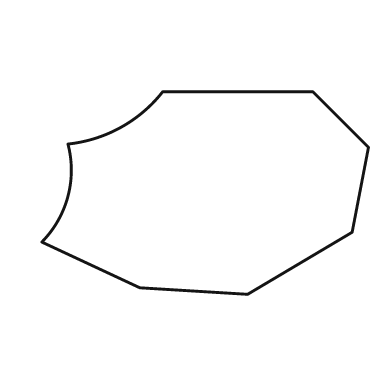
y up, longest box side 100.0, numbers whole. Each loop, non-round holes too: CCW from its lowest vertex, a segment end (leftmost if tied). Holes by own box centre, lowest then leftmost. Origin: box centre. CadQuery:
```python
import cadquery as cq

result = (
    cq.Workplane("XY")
    .moveTo(13.0, -31.0)
    .lineTo(45.0, -12.0)
    .lineTo(50.0, 14.0)
    .lineTo(33.0, 31.0)
    .lineTo(-13.0, 31.0)
    .threePointArc((-26.0, 20.0), (-42.0, 15.0))
    .threePointArc((-42.0, -1.0), (-50.0, -15.0))
    .lineTo(-20.0, -29.0)
    .close()
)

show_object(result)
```